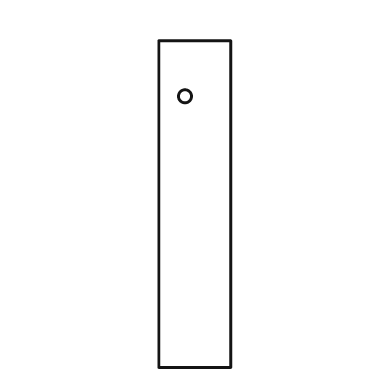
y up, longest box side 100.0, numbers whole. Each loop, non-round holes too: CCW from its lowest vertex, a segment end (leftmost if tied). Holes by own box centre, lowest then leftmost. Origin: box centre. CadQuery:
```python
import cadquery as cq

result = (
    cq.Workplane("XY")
    .moveTo(-11.0, -50.0)
    .lineTo(11.0, -50.0)
    .lineTo(11.0, 50.0)
    .lineTo(-11.0, 50.0)
    .close()
    .moveTo(-3.0, 33.0)
    .circle(2.0)
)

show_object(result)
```